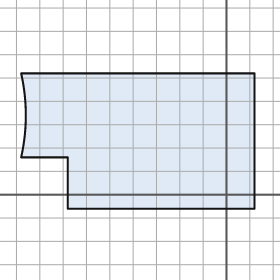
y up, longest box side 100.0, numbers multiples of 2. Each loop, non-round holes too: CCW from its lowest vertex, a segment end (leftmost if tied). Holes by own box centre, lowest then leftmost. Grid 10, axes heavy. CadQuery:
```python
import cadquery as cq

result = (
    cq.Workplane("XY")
    .moveTo(-68.0, -6.0)
    .lineTo(12.0, -6.0)
    .lineTo(12.0, 52.0)
    .lineTo(-88.0, 52.0)
    .threePointArc((-86.0, 34.0), (-88.0, 16.0))
    .lineTo(-68.0, 16.0)
    .close()
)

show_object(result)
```